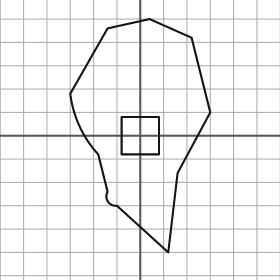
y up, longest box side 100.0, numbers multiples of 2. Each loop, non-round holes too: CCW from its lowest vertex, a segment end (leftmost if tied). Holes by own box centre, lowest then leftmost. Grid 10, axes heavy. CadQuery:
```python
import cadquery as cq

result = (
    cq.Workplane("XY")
    .moveTo(12.0, -50.0)
    .lineTo(16.0, -16.0)
    .lineTo(30.0, 10.0)
    .lineTo(22.0, 42.0)
    .lineTo(4.0, 50.0)
    .lineTo(-14.0, 46.0)
    .lineTo(-30.0, 18.0)
    .threePointArc((-26.0, 4.0), (-18.0, -8.0))
    .lineTo(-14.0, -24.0)
    .threePointArc((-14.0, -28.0), (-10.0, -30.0))
    .close()
    .moveTo(-8.0, -8.0)
    .lineTo(8.0, -8.0)
    .lineTo(8.0, 8.0)
    .lineTo(-8.0, 8.0)
    .close()
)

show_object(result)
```